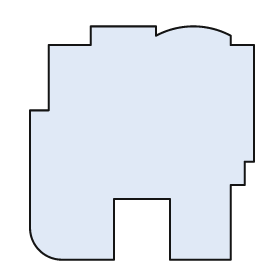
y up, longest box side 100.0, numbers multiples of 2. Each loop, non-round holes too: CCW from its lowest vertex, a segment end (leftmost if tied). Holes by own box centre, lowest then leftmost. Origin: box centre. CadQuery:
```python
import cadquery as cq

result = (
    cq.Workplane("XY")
    .moveTo(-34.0, -50.0)
    .lineTo(-12.0, -50.0)
    .lineTo(-12.0, -24.0)
    .lineTo(12.0, -24.0)
    .lineTo(12.0, -50.0)
    .lineTo(38.0, -50.0)
    .lineTo(38.0, -18.0)
    .lineTo(44.0, -18.0)
    .lineTo(44.0, -8.0)
    .lineTo(48.0, -8.0)
    .lineTo(48.0, 42.0)
    .lineTo(38.0, 42.0)
    .lineTo(38.0, 46.0)
    .threePointArc((22.0, 50.0), (6.0, 46.0))
    .lineTo(6.0, 50.0)
    .lineTo(-22.0, 50.0)
    .lineTo(-22.0, 42.0)
    .lineTo(-40.0, 42.0)
    .lineTo(-40.0, 14.0)
    .lineTo(-48.0, 14.0)
    .lineTo(-48.0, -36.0)
    .threePointArc((-44.0, -46.0), (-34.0, -50.0))
    .close()
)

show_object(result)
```